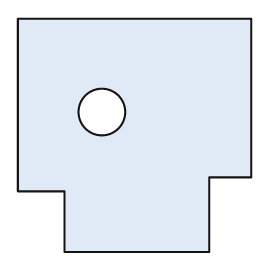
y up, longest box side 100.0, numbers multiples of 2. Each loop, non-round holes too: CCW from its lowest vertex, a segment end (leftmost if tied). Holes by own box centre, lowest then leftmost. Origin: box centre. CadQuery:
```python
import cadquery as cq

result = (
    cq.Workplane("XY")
    .moveTo(-30.0, -50.0)
    .lineTo(32.0, -50.0)
    .lineTo(32.0, -18.0)
    .lineTo(50.0, -18.0)
    .lineTo(50.0, 50.0)
    .lineTo(-50.0, 50.0)
    .lineTo(-50.0, -24.0)
    .lineTo(-30.0, -24.0)
    .close()
    .moveTo(-14.0, 10.0)
    .circle(10.0)
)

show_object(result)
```